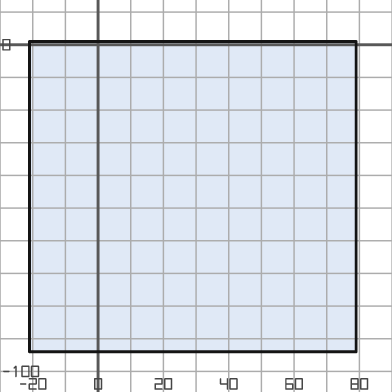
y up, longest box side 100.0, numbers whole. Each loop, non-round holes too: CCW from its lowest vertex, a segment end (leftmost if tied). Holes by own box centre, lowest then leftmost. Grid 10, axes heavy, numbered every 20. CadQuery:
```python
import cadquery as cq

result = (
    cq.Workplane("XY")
    .moveTo(-21.0, -94.0)
    .lineTo(79.0, -94.0)
    .lineTo(79.0, 1.0)
    .lineTo(-21.0, 1.0)
    .close()
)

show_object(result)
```